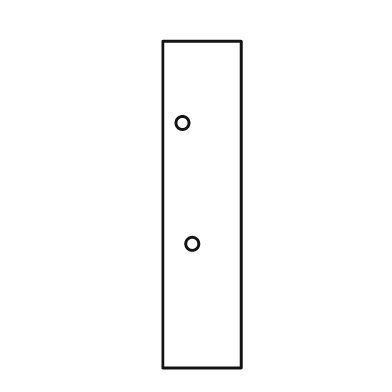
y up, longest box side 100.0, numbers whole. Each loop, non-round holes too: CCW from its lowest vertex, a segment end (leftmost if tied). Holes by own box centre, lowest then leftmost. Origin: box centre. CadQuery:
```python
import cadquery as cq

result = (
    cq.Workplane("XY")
    .moveTo(-12.0, -50.0)
    .lineTo(12.0, -50.0)
    .lineTo(12.0, 50.0)
    .lineTo(-12.0, 50.0)
    .close()
    .moveTo(-3.0, -12.0)
    .circle(2.0)
    .moveTo(-6.0, 25.0)
    .circle(2.0)
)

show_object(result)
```